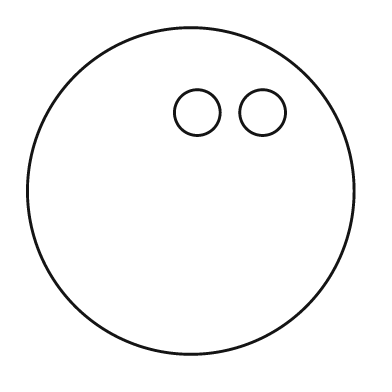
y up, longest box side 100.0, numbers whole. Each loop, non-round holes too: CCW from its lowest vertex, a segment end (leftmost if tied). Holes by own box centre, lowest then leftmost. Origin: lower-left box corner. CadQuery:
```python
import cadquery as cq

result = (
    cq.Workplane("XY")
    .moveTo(50.0, 50.0)
    .circle(50.0)
    .moveTo(52.0, 74.0)
    .circle(7.0)
    .moveTo(72.0, 74.0)
    .circle(7.0)
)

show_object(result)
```